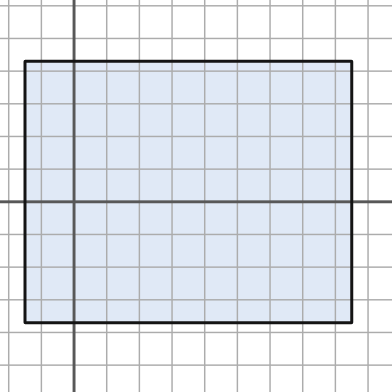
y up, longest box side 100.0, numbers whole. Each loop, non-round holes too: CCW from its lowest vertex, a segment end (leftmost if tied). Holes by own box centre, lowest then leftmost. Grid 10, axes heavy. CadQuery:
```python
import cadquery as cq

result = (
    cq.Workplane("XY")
    .moveTo(-15.0, -37.0)
    .lineTo(85.0, -37.0)
    .lineTo(85.0, 43.0)
    .lineTo(-15.0, 43.0)
    .close()
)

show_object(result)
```